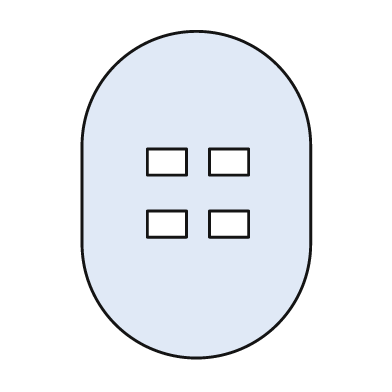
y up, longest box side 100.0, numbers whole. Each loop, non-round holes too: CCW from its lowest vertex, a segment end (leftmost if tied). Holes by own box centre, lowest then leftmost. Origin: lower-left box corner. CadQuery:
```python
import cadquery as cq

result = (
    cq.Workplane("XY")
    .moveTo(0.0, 35.0)
    .threePointArc((35.0, 0.0), (70.0, 35.0))
    .lineTo(70.0, 65.0)
    .threePointArc((35.0, 100.0), (0.0, 65.0))
    .close()
    .moveTo(20.0, 37.0)
    .lineTo(32.0, 37.0)
    .lineTo(32.0, 45.0)
    .lineTo(20.0, 45.0)
    .close()
    .moveTo(39.0, 37.0)
    .lineTo(51.0, 37.0)
    .lineTo(51.0, 45.0)
    .lineTo(39.0, 45.0)
    .close()
    .moveTo(20.0, 56.0)
    .lineTo(32.0, 56.0)
    .lineTo(32.0, 64.0)
    .lineTo(20.0, 64.0)
    .close()
    .moveTo(39.0, 56.0)
    .lineTo(51.0, 56.0)
    .lineTo(51.0, 64.0)
    .lineTo(39.0, 64.0)
    .close()
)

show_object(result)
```